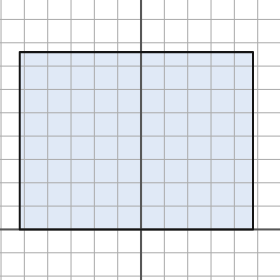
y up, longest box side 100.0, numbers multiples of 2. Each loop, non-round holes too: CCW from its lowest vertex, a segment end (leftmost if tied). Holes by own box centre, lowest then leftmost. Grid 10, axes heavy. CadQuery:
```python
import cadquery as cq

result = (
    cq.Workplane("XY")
    .moveTo(-52.0, 0.0)
    .lineTo(48.0, 0.0)
    .lineTo(48.0, 76.0)
    .lineTo(-52.0, 76.0)
    .close()
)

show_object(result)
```